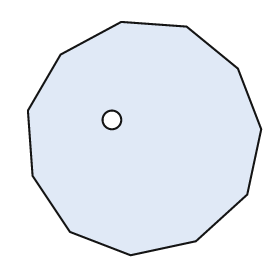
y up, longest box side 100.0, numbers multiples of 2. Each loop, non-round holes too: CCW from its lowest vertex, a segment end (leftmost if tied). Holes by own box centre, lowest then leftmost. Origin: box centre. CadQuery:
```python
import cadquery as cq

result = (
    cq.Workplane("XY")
    .moveTo(-6.0, -50.0)
    .lineTo(22.0, -44.0)
    .lineTo(44.0, -24.0)
    .lineTo(50.0, 4.0)
    .lineTo(40.0, 30.0)
    .lineTo(18.0, 48.0)
    .lineTo(-10.0, 50.0)
    .lineTo(-36.0, 36.0)
    .lineTo(-50.0, 12.0)
    .lineTo(-48.0, -16.0)
    .lineTo(-32.0, -40.0)
    .close()
    .moveTo(-14.0, 8.0)
    .circle(4.0)
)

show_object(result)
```